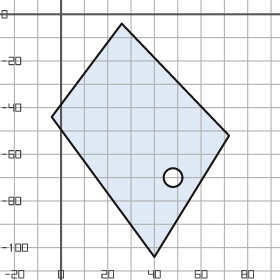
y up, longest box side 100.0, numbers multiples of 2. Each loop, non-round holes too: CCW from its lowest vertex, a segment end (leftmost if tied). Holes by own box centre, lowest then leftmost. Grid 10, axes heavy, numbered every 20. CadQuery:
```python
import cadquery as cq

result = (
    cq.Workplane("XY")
    .moveTo(40.0, -104.0)
    .lineTo(72.0, -52.0)
    .lineTo(26.0, -4.0)
    .lineTo(-4.0, -44.0)
    .close()
    .moveTo(48.0, -70.0)
    .circle(4.0)
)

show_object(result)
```